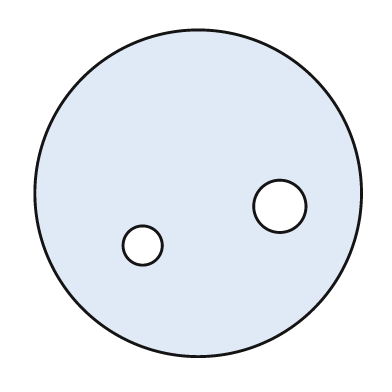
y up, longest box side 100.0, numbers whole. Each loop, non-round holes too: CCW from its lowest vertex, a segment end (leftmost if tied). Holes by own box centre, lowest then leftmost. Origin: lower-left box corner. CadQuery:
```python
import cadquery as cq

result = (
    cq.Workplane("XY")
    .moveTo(50.0, 50.0)
    .circle(50.0)
    .moveTo(33.0, 34.0)
    .circle(6.0)
    .moveTo(75.0, 46.0)
    .circle(8.0)
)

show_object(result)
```